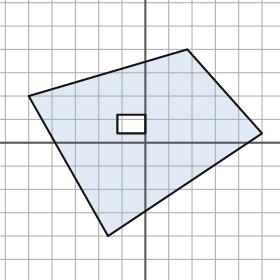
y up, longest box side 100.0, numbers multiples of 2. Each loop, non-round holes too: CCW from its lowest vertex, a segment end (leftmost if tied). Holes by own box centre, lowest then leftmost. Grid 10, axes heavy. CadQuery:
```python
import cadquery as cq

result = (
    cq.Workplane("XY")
    .moveTo(-16.0, -40.0)
    .lineTo(50.0, 4.0)
    .lineTo(18.0, 40.0)
    .lineTo(-50.0, 20.0)
    .close()
    .moveTo(-12.0, 4.0)
    .lineTo(0.0, 4.0)
    .lineTo(0.0, 12.0)
    .lineTo(-12.0, 12.0)
    .close()
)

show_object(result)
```